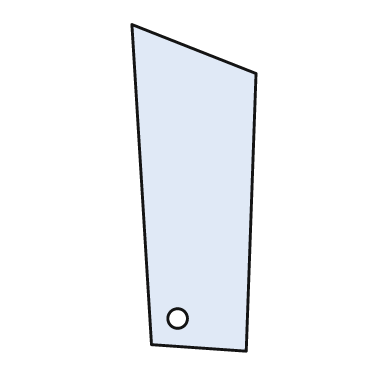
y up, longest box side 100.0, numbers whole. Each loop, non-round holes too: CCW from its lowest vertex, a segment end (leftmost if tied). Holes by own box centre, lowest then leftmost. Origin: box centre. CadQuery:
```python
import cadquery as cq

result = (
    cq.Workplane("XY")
    .moveTo(16.0, -50.0)
    .lineTo(19.0, 35.0)
    .lineTo(-19.0, 50.0)
    .lineTo(-13.0, -48.0)
    .close()
    .moveTo(-5.0, -40.0)
    .circle(3.0)
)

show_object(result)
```